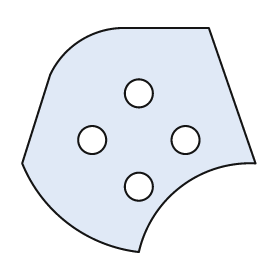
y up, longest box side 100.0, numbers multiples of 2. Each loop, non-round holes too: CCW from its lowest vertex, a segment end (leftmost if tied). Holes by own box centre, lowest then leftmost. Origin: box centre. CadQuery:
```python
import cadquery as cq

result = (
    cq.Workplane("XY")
    .moveTo(0.0, -48.0)
    .threePointArc((18.0, -20.0), (50.0, -10.0))
    .lineTo(30.0, 48.0)
    .lineTo(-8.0, 48.0)
    .threePointArc((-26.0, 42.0), (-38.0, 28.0))
    .lineTo(-50.0, -10.0)
    .threePointArc((-30.0, -36.0), (0.0, -48.0))
    .close()
    .moveTo(0.0, -20.0)
    .circle(6.0)
    .moveTo(-20.0, 0.0)
    .circle(6.0)
    .moveTo(20.0, 0.0)
    .circle(6.0)
    .moveTo(0.0, 20.0)
    .circle(6.0)
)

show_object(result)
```